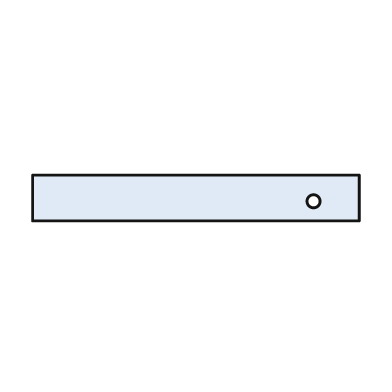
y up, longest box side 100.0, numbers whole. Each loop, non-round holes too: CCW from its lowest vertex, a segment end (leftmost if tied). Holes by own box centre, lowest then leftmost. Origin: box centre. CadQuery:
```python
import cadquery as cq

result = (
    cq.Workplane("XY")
    .moveTo(-50.0, -7.0)
    .lineTo(50.0, -7.0)
    .lineTo(50.0, 7.0)
    .lineTo(-50.0, 7.0)
    .close()
    .moveTo(36.0, -1.0)
    .circle(2.0)
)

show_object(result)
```